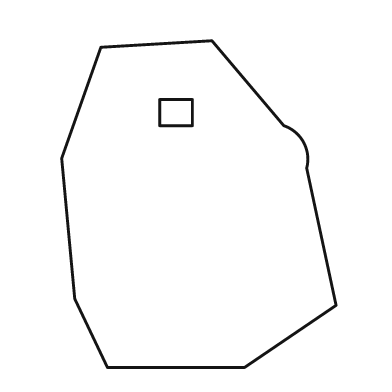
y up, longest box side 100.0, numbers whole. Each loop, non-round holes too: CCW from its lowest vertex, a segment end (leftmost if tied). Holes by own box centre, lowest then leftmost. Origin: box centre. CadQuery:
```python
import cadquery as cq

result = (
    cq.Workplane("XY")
    .moveTo(-28.0, -50.0)
    .lineTo(14.0, -50.0)
    .lineTo(42.0, -31.0)
    .lineTo(33.0, 11.0)
    .threePointArc((32.0, 19.0), (26.0, 24.0))
    .lineTo(4.0, 50.0)
    .lineTo(-30.0, 48.0)
    .lineTo(-42.0, 14.0)
    .lineTo(-38.0, -29.0)
    .close()
    .moveTo(-12.0, 24.0)
    .lineTo(-2.0, 24.0)
    .lineTo(-2.0, 32.0)
    .lineTo(-12.0, 32.0)
    .close()
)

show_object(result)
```